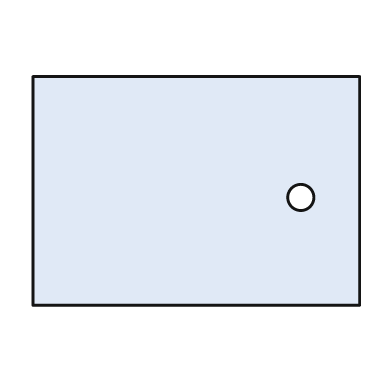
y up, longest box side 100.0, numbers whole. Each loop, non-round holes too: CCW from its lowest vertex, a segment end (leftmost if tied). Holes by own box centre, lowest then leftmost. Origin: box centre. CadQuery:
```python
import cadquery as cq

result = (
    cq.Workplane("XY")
    .moveTo(-50.0, -35.0)
    .lineTo(50.0, -35.0)
    .lineTo(50.0, 35.0)
    .lineTo(-50.0, 35.0)
    .close()
    .moveTo(32.0, -2.0)
    .circle(4.0)
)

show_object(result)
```